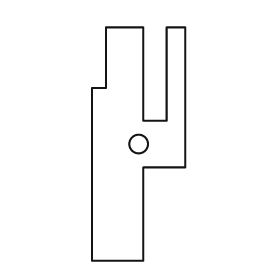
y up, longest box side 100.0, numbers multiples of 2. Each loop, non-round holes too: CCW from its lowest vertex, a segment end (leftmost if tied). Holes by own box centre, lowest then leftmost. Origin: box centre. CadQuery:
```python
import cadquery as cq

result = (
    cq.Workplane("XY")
    .moveTo(-20.0, -50.0)
    .lineTo(2.0, -50.0)
    .lineTo(2.0, -10.0)
    .lineTo(20.0, -10.0)
    .lineTo(20.0, 50.0)
    .lineTo(12.0, 50.0)
    .lineTo(12.0, 10.0)
    .lineTo(2.0, 10.0)
    .lineTo(2.0, 50.0)
    .lineTo(-14.0, 50.0)
    .lineTo(-14.0, 24.0)
    .lineTo(-20.0, 24.0)
    .close()
    .moveTo(0.0, 0.0)
    .circle(4.0)
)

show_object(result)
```